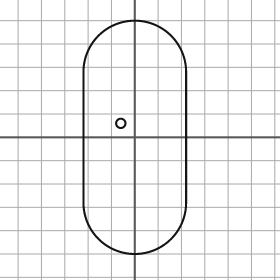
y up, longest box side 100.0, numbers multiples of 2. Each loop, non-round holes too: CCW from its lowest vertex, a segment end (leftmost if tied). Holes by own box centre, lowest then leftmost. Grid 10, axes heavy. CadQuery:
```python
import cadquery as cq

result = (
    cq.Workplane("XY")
    .moveTo(-22.0, -28.0)
    .threePointArc((0.0, -50.0), (22.0, -28.0))
    .lineTo(22.0, 28.0)
    .threePointArc((0.0, 50.0), (-22.0, 28.0))
    .close()
    .moveTo(-6.0, 6.0)
    .circle(2.0)
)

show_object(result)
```